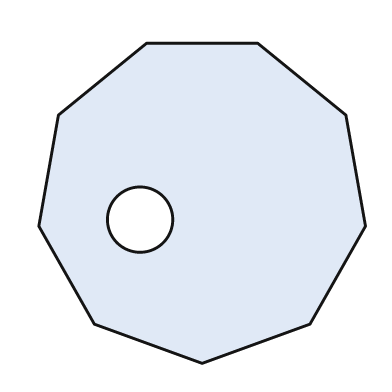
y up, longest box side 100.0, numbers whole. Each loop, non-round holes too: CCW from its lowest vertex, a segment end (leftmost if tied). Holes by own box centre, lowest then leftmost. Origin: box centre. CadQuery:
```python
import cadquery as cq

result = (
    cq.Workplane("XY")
    .moveTo(0.0, -49.0)
    .lineTo(33.0, -37.0)
    .lineTo(50.0, -7.0)
    .lineTo(44.0, 27.0)
    .lineTo(17.0, 49.0)
    .lineTo(-17.0, 49.0)
    .lineTo(-44.0, 27.0)
    .lineTo(-50.0, -7.0)
    .lineTo(-33.0, -37.0)
    .close()
    .moveTo(-19.0, -5.0)
    .circle(10.0)
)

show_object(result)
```